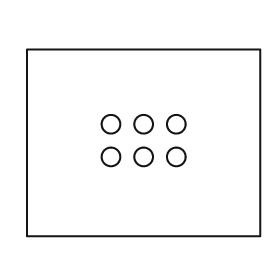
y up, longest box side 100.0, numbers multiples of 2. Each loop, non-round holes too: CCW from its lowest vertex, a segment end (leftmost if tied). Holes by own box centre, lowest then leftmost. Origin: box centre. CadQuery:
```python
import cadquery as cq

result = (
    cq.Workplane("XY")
    .moveTo(-50.0, -40.0)
    .lineTo(50.0, -40.0)
    .lineTo(50.0, 40.0)
    .lineTo(-50.0, 40.0)
    .close()
    .moveTo(-14.0, -6.0)
    .circle(4.0)
    .moveTo(0.0, -6.0)
    .circle(4.0)
    .moveTo(14.0, -6.0)
    .circle(4.0)
    .moveTo(-14.0, 8.0)
    .circle(4.0)
    .moveTo(0.0, 8.0)
    .circle(4.0)
    .moveTo(14.0, 8.0)
    .circle(4.0)
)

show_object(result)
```